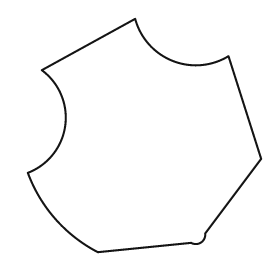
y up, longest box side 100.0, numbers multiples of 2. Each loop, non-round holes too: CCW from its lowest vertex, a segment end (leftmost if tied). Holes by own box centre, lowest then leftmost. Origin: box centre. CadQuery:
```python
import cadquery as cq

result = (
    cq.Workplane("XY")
    .moveTo(-20.0, -50.0)
    .lineTo(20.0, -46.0)
    .threePointArc((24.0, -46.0), (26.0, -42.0))
    .lineTo(50.0, -10.0)
    .lineTo(36.0, 34.0)
    .threePointArc((12.0, 32.0), (-4.0, 50.0))
    .lineTo(-44.0, 28.0)
    .threePointArc((-34.0, 4.0), (-50.0, -16.0))
    .threePointArc((-38.0, -36.0), (-20.0, -50.0))
    .close()
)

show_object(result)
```